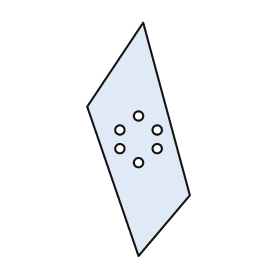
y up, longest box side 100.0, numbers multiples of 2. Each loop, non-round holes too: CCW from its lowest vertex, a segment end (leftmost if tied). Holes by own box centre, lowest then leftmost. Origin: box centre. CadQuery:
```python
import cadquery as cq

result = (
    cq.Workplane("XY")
    .moveTo(0.0, -50.0)
    .lineTo(22.0, -24.0)
    .lineTo(2.0, 50.0)
    .lineTo(-22.0, 14.0)
    .close()
    .moveTo(0.0, -10.0)
    .circle(2.0)
    .moveTo(-8.0, -4.0)
    .circle(2.0)
    .moveTo(8.0, -4.0)
    .circle(2.0)
    .moveTo(-8.0, 4.0)
    .circle(2.0)
    .moveTo(8.0, 4.0)
    .circle(2.0)
    .moveTo(0.0, 10.0)
    .circle(2.0)
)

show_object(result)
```